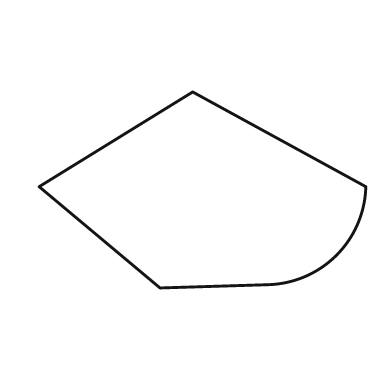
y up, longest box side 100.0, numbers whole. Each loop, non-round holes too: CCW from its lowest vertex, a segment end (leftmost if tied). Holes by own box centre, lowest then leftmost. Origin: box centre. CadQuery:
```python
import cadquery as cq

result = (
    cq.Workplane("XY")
    .moveTo(-13.0, -30.0)
    .lineTo(20.0, -29.0)
    .threePointArc((41.0, -20.0), (50.0, 1.0))
    .lineTo(-3.0, 30.0)
    .lineTo(-50.0, 1.0)
    .close()
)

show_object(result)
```